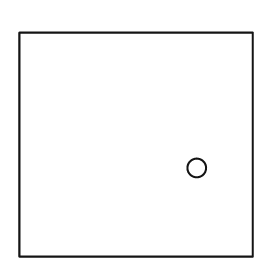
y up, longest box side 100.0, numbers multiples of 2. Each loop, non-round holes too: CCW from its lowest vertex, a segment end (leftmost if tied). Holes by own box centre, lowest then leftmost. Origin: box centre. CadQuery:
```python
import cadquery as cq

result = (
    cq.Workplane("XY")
    .moveTo(-50.0, -48.0)
    .lineTo(50.0, -48.0)
    .lineTo(50.0, 48.0)
    .lineTo(-50.0, 48.0)
    .close()
    .moveTo(26.0, -10.0)
    .circle(4.0)
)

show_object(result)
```